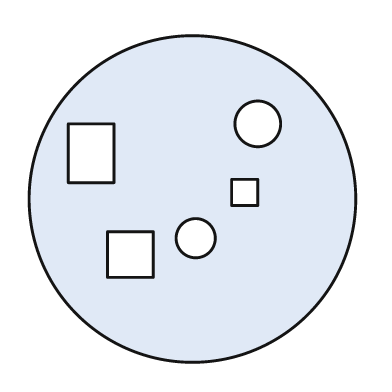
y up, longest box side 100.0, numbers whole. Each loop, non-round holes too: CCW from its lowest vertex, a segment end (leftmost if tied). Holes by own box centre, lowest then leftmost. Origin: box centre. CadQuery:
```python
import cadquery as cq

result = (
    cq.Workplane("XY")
    .moveTo(0.0, 0.0)
    .circle(50.0)
    .moveTo(-26.0, -24.0)
    .lineTo(-12.0, -24.0)
    .lineTo(-12.0, -10.0)
    .lineTo(-26.0, -10.0)
    .close()
    .moveTo(1.0, -12.0)
    .circle(6.0)
    .moveTo(12.0, -2.0)
    .lineTo(20.0, -2.0)
    .lineTo(20.0, 6.0)
    .lineTo(12.0, 6.0)
    .close()
    .moveTo(-38.0, 5.0)
    .lineTo(-24.0, 5.0)
    .lineTo(-24.0, 23.0)
    .lineTo(-38.0, 23.0)
    .close()
    .moveTo(20.0, 23.0)
    .circle(7.0)
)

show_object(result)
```